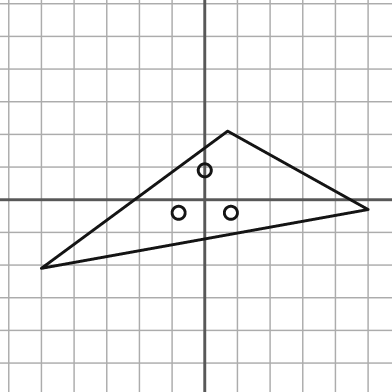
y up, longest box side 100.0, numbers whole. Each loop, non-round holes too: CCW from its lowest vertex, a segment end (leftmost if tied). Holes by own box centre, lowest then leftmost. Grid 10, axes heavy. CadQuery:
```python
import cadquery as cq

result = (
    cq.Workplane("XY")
    .moveTo(-50.0, -21.0)
    .lineTo(50.0, -3.0)
    .lineTo(7.0, 21.0)
    .close()
    .moveTo(-8.0, -4.0)
    .circle(2.0)
    .moveTo(8.0, -4.0)
    .circle(2.0)
    .moveTo(0.0, 9.0)
    .circle(2.0)
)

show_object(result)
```